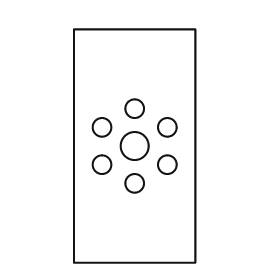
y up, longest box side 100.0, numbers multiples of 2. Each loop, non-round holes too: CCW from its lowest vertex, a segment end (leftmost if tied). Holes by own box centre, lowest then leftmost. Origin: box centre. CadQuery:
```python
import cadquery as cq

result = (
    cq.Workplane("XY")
    .moveTo(-26.0, -50.0)
    .lineTo(26.0, -50.0)
    .lineTo(26.0, 50.0)
    .lineTo(-26.0, 50.0)
    .close()
    .moveTo(0.0, -16.0)
    .circle(4.0)
    .moveTo(-14.0, -8.0)
    .circle(4.0)
    .moveTo(14.0, -8.0)
    .circle(4.0)
    .moveTo(0.0, 0.0)
    .circle(6.0)
    .moveTo(-14.0, 8.0)
    .circle(4.0)
    .moveTo(14.0, 8.0)
    .circle(4.0)
    .moveTo(0.0, 16.0)
    .circle(4.0)
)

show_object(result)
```